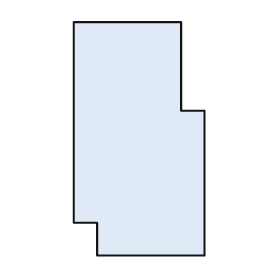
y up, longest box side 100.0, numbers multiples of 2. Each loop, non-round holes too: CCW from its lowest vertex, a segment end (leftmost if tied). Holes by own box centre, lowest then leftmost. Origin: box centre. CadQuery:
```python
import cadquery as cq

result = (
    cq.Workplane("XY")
    .moveTo(-18.0, -50.0)
    .lineTo(28.0, -50.0)
    .lineTo(28.0, 12.0)
    .lineTo(18.0, 12.0)
    .lineTo(18.0, 50.0)
    .lineTo(-28.0, 50.0)
    .lineTo(-28.0, -36.0)
    .lineTo(-18.0, -36.0)
    .close()
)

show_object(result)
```